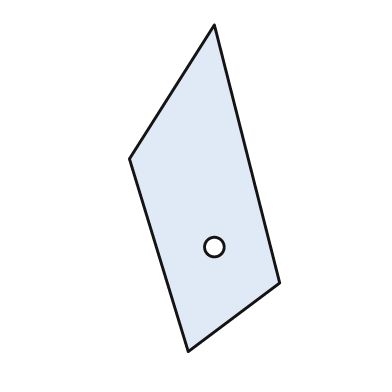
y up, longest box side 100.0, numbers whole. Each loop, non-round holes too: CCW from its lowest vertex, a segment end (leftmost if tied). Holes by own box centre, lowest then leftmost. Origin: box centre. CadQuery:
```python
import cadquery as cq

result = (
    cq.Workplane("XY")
    .moveTo(-5.0, -50.0)
    .lineTo(23.0, -29.0)
    .lineTo(3.0, 50.0)
    .lineTo(-23.0, 9.0)
    .close()
    .moveTo(3.0, -18.0)
    .circle(3.0)
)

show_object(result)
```